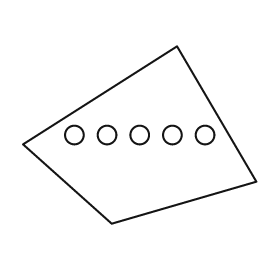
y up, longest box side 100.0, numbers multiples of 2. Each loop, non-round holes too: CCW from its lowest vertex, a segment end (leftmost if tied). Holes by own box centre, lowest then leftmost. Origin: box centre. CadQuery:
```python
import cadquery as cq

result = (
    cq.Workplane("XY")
    .moveTo(-12.0, -38.0)
    .lineTo(50.0, -20.0)
    .lineTo(16.0, 38.0)
    .lineTo(-50.0, -4.0)
    .close()
    .moveTo(-28.0, 0.0)
    .circle(4.0)
    .moveTo(-14.0, 0.0)
    .circle(4.0)
    .moveTo(0.0, 0.0)
    .circle(4.0)
    .moveTo(14.0, 0.0)
    .circle(4.0)
    .moveTo(28.0, 0.0)
    .circle(4.0)
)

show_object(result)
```